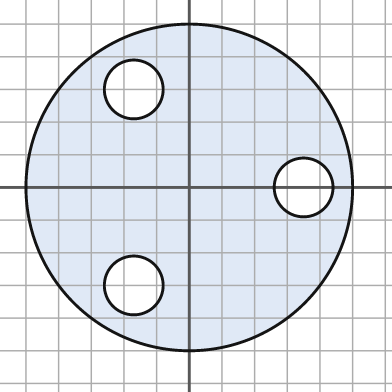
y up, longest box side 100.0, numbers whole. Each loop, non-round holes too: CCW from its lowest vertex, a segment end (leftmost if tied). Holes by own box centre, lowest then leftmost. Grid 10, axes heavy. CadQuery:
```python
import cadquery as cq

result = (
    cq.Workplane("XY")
    .moveTo(0.0, 0.0)
    .circle(50.0)
    .moveTo(-17.0, -30.0)
    .circle(9.0)
    .moveTo(35.0, 0.0)
    .circle(9.0)
    .moveTo(-17.0, 30.0)
    .circle(9.0)
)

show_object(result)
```